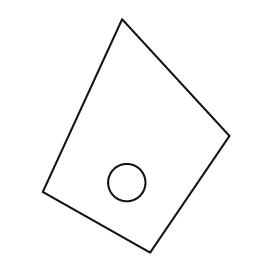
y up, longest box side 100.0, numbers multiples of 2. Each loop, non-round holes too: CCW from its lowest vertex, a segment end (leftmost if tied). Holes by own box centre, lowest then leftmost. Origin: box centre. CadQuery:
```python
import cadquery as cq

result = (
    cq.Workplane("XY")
    .moveTo(6.0, -50.0)
    .lineTo(40.0, 0.0)
    .lineTo(-6.0, 50.0)
    .lineTo(-40.0, -24.0)
    .close()
    .moveTo(-4.0, -20.0)
    .circle(8.0)
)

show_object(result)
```